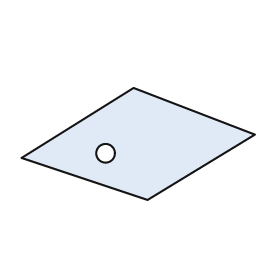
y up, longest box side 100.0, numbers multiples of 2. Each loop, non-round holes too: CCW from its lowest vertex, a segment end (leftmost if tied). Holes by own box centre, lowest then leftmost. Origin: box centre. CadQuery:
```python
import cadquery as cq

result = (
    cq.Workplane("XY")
    .moveTo(4.0, -24.0)
    .lineTo(50.0, 4.0)
    .lineTo(-2.0, 24.0)
    .lineTo(-50.0, -6.0)
    .close()
    .moveTo(-14.0, -4.0)
    .circle(4.0)
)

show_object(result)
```